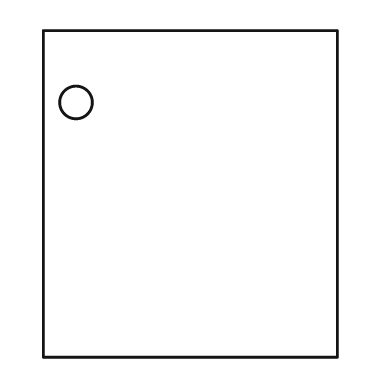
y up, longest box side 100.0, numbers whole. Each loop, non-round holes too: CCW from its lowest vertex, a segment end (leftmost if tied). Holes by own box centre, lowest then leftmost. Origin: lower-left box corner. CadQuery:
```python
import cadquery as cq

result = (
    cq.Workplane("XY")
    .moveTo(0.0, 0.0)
    .lineTo(90.0, 0.0)
    .lineTo(90.0, 100.0)
    .lineTo(0.0, 100.0)
    .close()
    .moveTo(10.0, 78.0)
    .circle(5.0)
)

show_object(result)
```